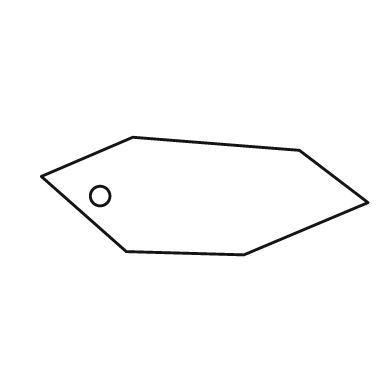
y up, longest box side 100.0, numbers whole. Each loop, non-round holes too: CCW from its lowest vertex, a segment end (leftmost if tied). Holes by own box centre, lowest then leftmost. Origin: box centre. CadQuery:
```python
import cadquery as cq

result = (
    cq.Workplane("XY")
    .moveTo(12.0, -18.0)
    .lineTo(50.0, -2.0)
    .lineTo(29.0, 14.0)
    .lineTo(-22.0, 18.0)
    .lineTo(-50.0, 6.0)
    .lineTo(-24.0, -17.0)
    .close()
    .moveTo(-32.0, 0.0)
    .circle(3.0)
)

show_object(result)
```